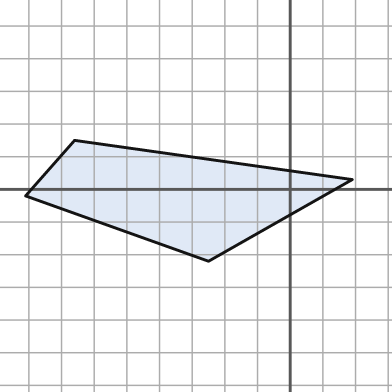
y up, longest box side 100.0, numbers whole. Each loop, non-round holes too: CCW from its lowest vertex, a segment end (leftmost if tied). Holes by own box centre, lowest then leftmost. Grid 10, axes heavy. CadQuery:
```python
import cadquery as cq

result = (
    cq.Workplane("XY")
    .moveTo(-25.0, -22.0)
    .lineTo(19.0, 3.0)
    .lineTo(-66.0, 15.0)
    .lineTo(-81.0, -2.0)
    .close()
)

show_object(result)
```